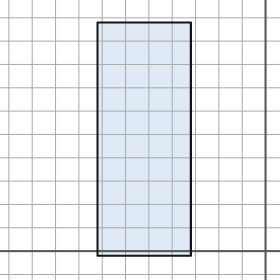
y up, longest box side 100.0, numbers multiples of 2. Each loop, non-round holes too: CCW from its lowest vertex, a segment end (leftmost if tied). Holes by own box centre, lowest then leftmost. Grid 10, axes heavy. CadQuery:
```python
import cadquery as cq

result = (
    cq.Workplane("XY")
    .moveTo(-72.0, -2.0)
    .lineTo(-32.0, -2.0)
    .lineTo(-32.0, 98.0)
    .lineTo(-72.0, 98.0)
    .close()
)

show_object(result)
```